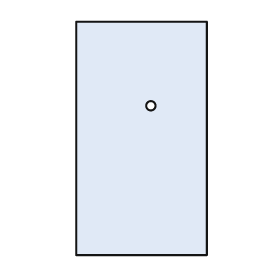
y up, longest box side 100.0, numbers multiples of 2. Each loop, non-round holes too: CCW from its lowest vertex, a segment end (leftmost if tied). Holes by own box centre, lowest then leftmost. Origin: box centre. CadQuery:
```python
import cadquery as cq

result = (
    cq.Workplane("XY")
    .moveTo(-28.0, -50.0)
    .lineTo(28.0, -50.0)
    .lineTo(28.0, 50.0)
    .lineTo(-28.0, 50.0)
    .close()
    .moveTo(4.0, 14.0)
    .circle(2.0)
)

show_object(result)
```